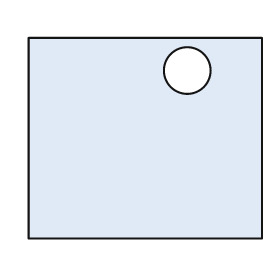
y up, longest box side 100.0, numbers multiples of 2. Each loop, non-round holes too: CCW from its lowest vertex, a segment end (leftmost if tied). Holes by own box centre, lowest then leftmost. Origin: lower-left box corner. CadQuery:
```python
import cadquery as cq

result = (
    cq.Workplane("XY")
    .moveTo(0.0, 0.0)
    .lineTo(100.0, 0.0)
    .lineTo(100.0, 86.0)
    .lineTo(0.0, 86.0)
    .close()
    .moveTo(68.0, 72.0)
    .circle(10.0)
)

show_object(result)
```